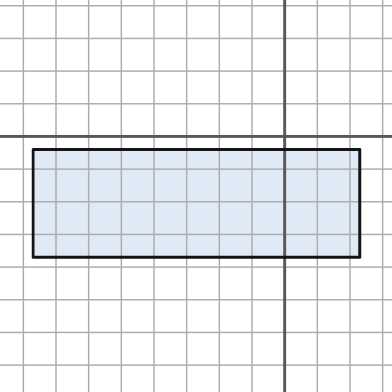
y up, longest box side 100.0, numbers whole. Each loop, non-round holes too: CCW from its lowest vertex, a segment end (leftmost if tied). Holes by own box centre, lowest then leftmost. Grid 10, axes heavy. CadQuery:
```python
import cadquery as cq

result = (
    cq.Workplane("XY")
    .moveTo(-77.0, -37.0)
    .lineTo(23.0, -37.0)
    .lineTo(23.0, -4.0)
    .lineTo(-77.0, -4.0)
    .close()
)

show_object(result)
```